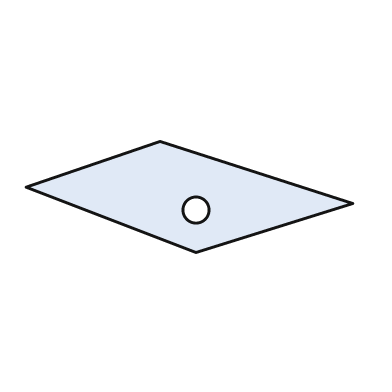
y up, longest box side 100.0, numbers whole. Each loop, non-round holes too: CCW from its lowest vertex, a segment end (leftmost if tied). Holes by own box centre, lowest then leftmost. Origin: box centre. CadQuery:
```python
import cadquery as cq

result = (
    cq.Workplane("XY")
    .moveTo(2.0, -17.0)
    .lineTo(50.0, -2.0)
    .lineTo(-9.0, 17.0)
    .lineTo(-50.0, 3.0)
    .close()
    .moveTo(2.0, -4.0)
    .circle(4.0)
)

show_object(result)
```